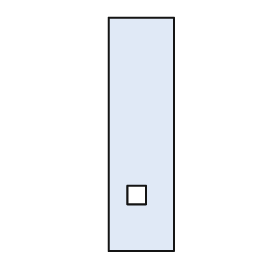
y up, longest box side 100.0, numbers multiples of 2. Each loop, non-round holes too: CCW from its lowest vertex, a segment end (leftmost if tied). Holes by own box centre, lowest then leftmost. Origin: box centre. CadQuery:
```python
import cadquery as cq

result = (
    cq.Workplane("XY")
    .moveTo(-14.0, -50.0)
    .lineTo(14.0, -50.0)
    .lineTo(14.0, 50.0)
    .lineTo(-14.0, 50.0)
    .close()
    .moveTo(-6.0, -30.0)
    .lineTo(2.0, -30.0)
    .lineTo(2.0, -22.0)
    .lineTo(-6.0, -22.0)
    .close()
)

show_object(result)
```